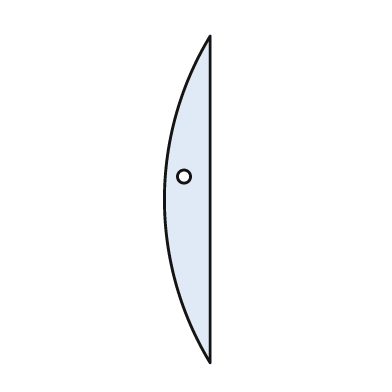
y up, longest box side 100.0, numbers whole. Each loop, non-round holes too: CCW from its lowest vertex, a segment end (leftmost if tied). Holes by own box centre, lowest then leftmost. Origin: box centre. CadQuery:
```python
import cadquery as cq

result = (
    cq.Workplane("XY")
    .moveTo(7.0, -50.0)
    .lineTo(7.0, 50.0)
    .threePointArc((-7.0, 0.0), (7.0, -50.0))
    .close()
    .moveTo(-1.0, 7.0)
    .circle(2.0)
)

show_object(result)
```